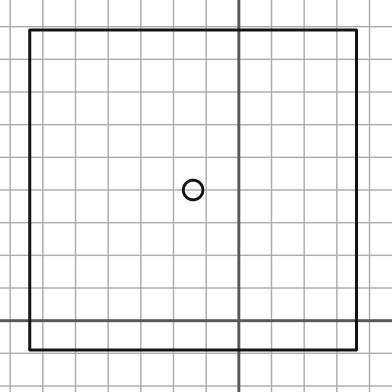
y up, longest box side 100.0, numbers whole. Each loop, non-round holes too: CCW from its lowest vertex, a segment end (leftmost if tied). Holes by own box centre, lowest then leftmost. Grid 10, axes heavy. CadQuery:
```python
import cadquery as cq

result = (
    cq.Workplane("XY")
    .moveTo(-64.0, -9.0)
    .lineTo(36.0, -9.0)
    .lineTo(36.0, 89.0)
    .lineTo(-64.0, 89.0)
    .close()
    .moveTo(-14.0, 40.0)
    .circle(3.0)
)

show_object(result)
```